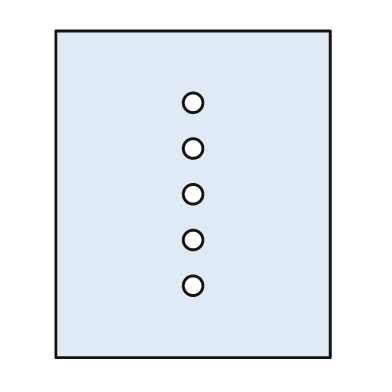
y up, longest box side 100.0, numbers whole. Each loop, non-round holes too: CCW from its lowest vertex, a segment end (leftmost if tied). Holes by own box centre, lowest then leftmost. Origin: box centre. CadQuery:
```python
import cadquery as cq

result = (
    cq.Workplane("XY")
    .moveTo(-42.0, -50.0)
    .lineTo(42.0, -50.0)
    .lineTo(42.0, 50.0)
    .lineTo(-42.0, 50.0)
    .close()
    .moveTo(0.0, -28.0)
    .circle(3.0)
    .moveTo(0.0, -14.0)
    .circle(3.0)
    .moveTo(0.0, 0.0)
    .circle(3.0)
    .moveTo(0.0, 14.0)
    .circle(3.0)
    .moveTo(0.0, 28.0)
    .circle(3.0)
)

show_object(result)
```